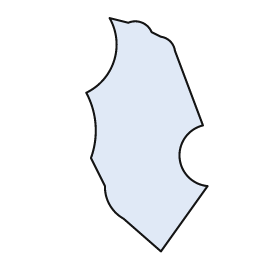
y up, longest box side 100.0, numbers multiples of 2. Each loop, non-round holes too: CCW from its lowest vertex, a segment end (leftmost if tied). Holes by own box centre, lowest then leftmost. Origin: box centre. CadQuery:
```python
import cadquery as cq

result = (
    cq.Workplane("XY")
    .moveTo(6.0, -50.0)
    .lineTo(26.0, -22.0)
    .threePointArc((14.0, -10.0), (24.0, 4.0))
    .lineTo(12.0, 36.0)
    .threePointArc((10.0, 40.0), (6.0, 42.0))
    .lineTo(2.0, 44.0)
    .threePointArc((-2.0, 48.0), (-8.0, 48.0))
    .lineTo(-16.0, 50.0)
    .threePointArc((-14.0, 32.0), (-26.0, 18.0))
    .threePointArc((-22.0, 4.0), (-24.0, -10.0))
    .lineTo(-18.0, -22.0)
    .threePointArc((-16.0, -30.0), (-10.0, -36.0))
    .close()
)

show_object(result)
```